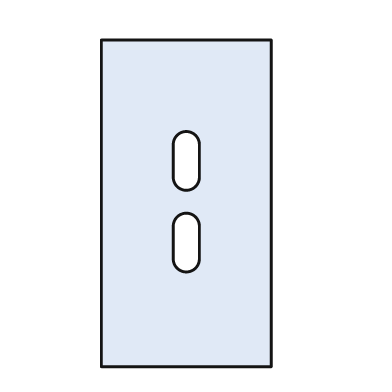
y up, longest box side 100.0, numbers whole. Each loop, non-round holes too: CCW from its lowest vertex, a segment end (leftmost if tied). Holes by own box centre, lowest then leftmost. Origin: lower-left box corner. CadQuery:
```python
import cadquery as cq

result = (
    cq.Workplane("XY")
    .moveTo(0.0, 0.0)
    .lineTo(52.0, 0.0)
    .lineTo(52.0, 100.0)
    .lineTo(0.0, 100.0)
    .close()
    .moveTo(22.0, 33.0)
    .threePointArc((26.0, 29.0), (30.0, 33.0))
    .lineTo(30.0, 43.0)
    .threePointArc((26.0, 47.0), (22.0, 43.0))
    .close()
    .moveTo(22.0, 58.0)
    .threePointArc((26.0, 54.0), (30.0, 58.0))
    .lineTo(30.0, 68.0)
    .threePointArc((26.0, 72.0), (22.0, 68.0))
    .close()
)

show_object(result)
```